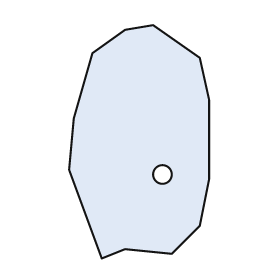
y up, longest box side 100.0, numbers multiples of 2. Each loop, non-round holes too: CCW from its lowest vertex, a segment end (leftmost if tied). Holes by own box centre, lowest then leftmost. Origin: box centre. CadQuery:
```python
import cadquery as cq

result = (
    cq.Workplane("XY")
    .moveTo(-16.0, -50.0)
    .lineTo(-6.0, -46.0)
    .lineTo(14.0, -48.0)
    .lineTo(26.0, -36.0)
    .lineTo(30.0, -16.0)
    .lineTo(30.0, 18.0)
    .lineTo(26.0, 36.0)
    .lineTo(6.0, 50.0)
    .lineTo(-6.0, 48.0)
    .lineTo(-20.0, 38.0)
    .lineTo(-28.0, 10.0)
    .lineTo(-30.0, -12.0)
    .close()
    .moveTo(10.0, -14.0)
    .circle(4.0)
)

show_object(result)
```